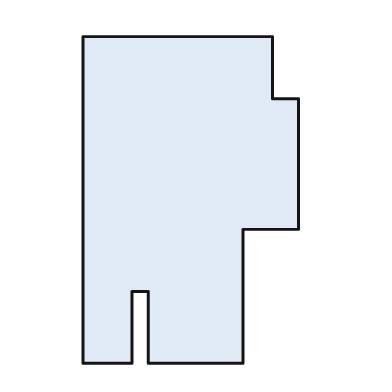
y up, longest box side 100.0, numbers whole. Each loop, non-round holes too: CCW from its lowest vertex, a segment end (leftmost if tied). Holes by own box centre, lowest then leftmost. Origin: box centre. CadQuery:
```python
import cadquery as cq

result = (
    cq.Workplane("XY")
    .moveTo(-33.0, -50.0)
    .lineTo(-18.0, -50.0)
    .lineTo(-18.0, -28.0)
    .lineTo(-13.0, -28.0)
    .lineTo(-13.0, -50.0)
    .lineTo(16.0, -50.0)
    .lineTo(16.0, -9.0)
    .lineTo(33.0, -9.0)
    .lineTo(33.0, 31.0)
    .lineTo(25.0, 31.0)
    .lineTo(25.0, 50.0)
    .lineTo(-33.0, 50.0)
    .close()
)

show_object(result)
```